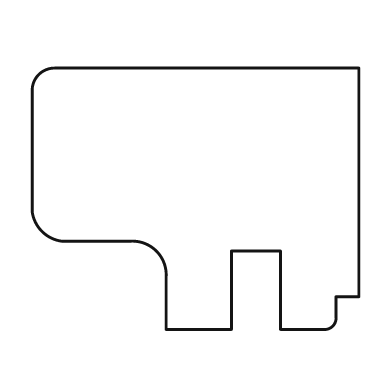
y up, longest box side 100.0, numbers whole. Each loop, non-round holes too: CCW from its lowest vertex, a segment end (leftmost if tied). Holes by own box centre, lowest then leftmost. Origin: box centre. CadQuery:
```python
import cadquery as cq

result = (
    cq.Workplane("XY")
    .moveTo(-9.0, -40.0)
    .lineTo(11.0, -40.0)
    .lineTo(11.0, -16.0)
    .lineTo(26.0, -16.0)
    .lineTo(26.0, -40.0)
    .lineTo(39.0, -40.0)
    .threePointArc((42.0, -39.0), (43.0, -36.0))
    .lineTo(43.0, -30.0)
    .lineTo(50.0, -30.0)
    .lineTo(50.0, 40.0)
    .lineTo(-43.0, 40.0)
    .threePointArc((-48.0, 38.0), (-50.0, 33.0))
    .lineTo(-50.0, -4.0)
    .threePointArc((-47.0, -10.0), (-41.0, -13.0))
    .lineTo(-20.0, -13.0)
    .threePointArc((-12.0, -16.0), (-9.0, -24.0))
    .close()
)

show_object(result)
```